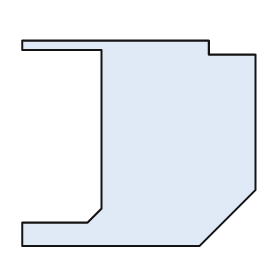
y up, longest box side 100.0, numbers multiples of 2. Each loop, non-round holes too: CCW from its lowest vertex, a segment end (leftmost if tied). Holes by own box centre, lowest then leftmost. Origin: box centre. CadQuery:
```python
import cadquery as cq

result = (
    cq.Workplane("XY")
    .moveTo(-50.0, -44.0)
    .lineTo(26.0, -44.0)
    .lineTo(50.0, -20.0)
    .lineTo(50.0, 38.0)
    .lineTo(30.0, 38.0)
    .lineTo(30.0, 44.0)
    .lineTo(-50.0, 44.0)
    .lineTo(-50.0, 40.0)
    .lineTo(-16.0, 40.0)
    .lineTo(-16.0, -28.0)
    .lineTo(-22.0, -34.0)
    .lineTo(-50.0, -34.0)
    .close()
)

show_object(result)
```